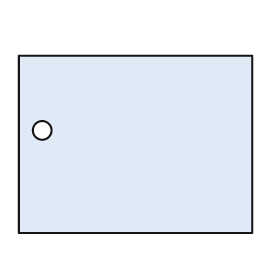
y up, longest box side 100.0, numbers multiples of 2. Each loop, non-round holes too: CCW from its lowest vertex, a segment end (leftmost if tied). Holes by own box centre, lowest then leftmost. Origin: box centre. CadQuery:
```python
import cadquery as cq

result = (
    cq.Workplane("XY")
    .moveTo(-50.0, -38.0)
    .lineTo(50.0, -38.0)
    .lineTo(50.0, 38.0)
    .lineTo(-50.0, 38.0)
    .close()
    .moveTo(-40.0, 6.0)
    .circle(4.0)
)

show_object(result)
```